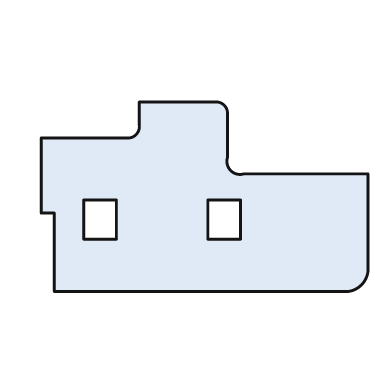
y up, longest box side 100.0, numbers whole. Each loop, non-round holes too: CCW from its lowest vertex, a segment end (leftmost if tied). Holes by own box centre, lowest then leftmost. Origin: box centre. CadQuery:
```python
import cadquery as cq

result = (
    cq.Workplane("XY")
    .moveTo(-46.0, -29.0)
    .lineTo(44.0, -29.0)
    .threePointArc((48.0, -27.0), (50.0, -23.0))
    .lineTo(50.0, 7.0)
    .lineTo(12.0, 7.0)
    .threePointArc((8.0, 8.0), (7.0, 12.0))
    .lineTo(7.0, 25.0)
    .threePointArc((6.0, 28.0), (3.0, 29.0))
    .lineTo(-20.0, 29.0)
    .lineTo(-20.0, 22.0)
    .threePointArc((-21.0, 19.0), (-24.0, 18.0))
    .lineTo(-50.0, 18.0)
    .lineTo(-50.0, -5.0)
    .lineTo(-46.0, -5.0)
    .close()
    .moveTo(-37.0, -13.0)
    .lineTo(-27.0, -13.0)
    .lineTo(-27.0, -1.0)
    .lineTo(-37.0, -1.0)
    .close()
    .moveTo(1.0, -13.0)
    .lineTo(11.0, -13.0)
    .lineTo(11.0, -1.0)
    .lineTo(1.0, -1.0)
    .close()
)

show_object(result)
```